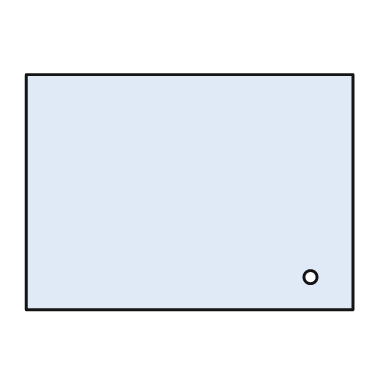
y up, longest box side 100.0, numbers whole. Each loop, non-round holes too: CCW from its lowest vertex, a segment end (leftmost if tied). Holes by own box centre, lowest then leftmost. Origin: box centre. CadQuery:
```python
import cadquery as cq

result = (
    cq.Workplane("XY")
    .moveTo(-50.0, -36.0)
    .lineTo(50.0, -36.0)
    .lineTo(50.0, 36.0)
    .lineTo(-50.0, 36.0)
    .close()
    .moveTo(37.0, -26.0)
    .circle(2.0)
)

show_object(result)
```